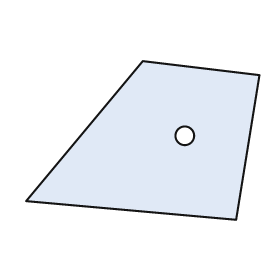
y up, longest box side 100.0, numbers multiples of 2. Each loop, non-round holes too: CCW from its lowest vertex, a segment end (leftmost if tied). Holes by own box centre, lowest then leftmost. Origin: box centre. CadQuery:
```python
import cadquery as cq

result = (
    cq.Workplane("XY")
    .moveTo(40.0, -34.0)
    .lineTo(50.0, 28.0)
    .lineTo(0.0, 34.0)
    .lineTo(-50.0, -26.0)
    .close()
    .moveTo(18.0, 2.0)
    .circle(4.0)
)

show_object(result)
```